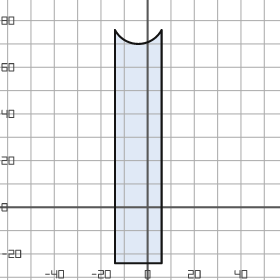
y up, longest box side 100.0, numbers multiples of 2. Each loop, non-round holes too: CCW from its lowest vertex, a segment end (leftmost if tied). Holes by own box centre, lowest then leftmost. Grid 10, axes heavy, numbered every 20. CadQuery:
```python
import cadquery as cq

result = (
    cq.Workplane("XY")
    .moveTo(-14.0, -24.0)
    .lineTo(6.0, -24.0)
    .lineTo(6.0, 76.0)
    .threePointArc((-4.0, 70.0), (-14.0, 76.0))
    .close()
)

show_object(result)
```